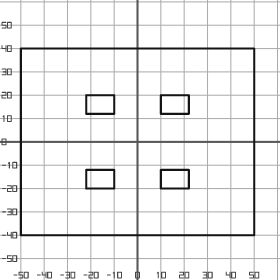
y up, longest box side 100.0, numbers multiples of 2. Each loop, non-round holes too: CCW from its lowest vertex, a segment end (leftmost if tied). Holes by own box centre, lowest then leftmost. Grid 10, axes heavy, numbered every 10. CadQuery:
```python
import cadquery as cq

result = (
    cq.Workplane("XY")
    .moveTo(-50.0, -40.0)
    .lineTo(50.0, -40.0)
    .lineTo(50.0, 40.0)
    .lineTo(-50.0, 40.0)
    .close()
    .moveTo(-22.0, -20.0)
    .lineTo(-10.0, -20.0)
    .lineTo(-10.0, -12.0)
    .lineTo(-22.0, -12.0)
    .close()
    .moveTo(10.0, -20.0)
    .lineTo(22.0, -20.0)
    .lineTo(22.0, -12.0)
    .lineTo(10.0, -12.0)
    .close()
    .moveTo(-22.0, 12.0)
    .lineTo(-10.0, 12.0)
    .lineTo(-10.0, 20.0)
    .lineTo(-22.0, 20.0)
    .close()
    .moveTo(10.0, 12.0)
    .lineTo(22.0, 12.0)
    .lineTo(22.0, 20.0)
    .lineTo(10.0, 20.0)
    .close()
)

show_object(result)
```